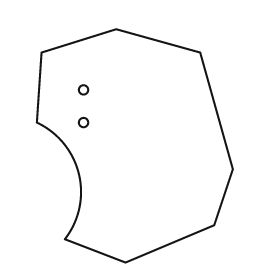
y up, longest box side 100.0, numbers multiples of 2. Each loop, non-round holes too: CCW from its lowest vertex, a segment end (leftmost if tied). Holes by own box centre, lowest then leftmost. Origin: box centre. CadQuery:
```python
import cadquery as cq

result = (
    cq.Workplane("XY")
    .moveTo(-4.0, -50.0)
    .lineTo(34.0, -34.0)
    .lineTo(42.0, -10.0)
    .lineTo(28.0, 40.0)
    .lineTo(-8.0, 50.0)
    .lineTo(-40.0, 40.0)
    .lineTo(-42.0, 10.0)
    .threePointArc((-24.0, -12.0), (-30.0, -40.0))
    .close()
    .moveTo(-22.0, 10.0)
    .circle(2.0)
    .moveTo(-22.0, 24.0)
    .circle(2.0)
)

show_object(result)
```